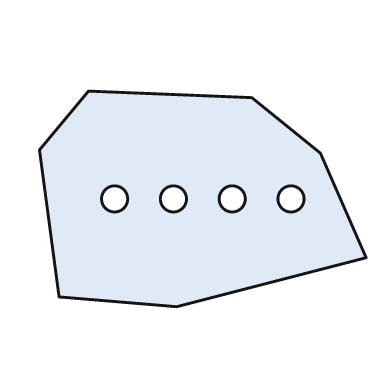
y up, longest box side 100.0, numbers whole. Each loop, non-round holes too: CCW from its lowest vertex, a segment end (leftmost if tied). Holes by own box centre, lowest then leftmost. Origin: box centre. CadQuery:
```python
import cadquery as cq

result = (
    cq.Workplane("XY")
    .moveTo(-8.0, -33.0)
    .lineTo(50.0, -18.0)
    .lineTo(36.0, 14.0)
    .lineTo(15.0, 31.0)
    .lineTo(-35.0, 33.0)
    .lineTo(-50.0, 15.0)
    .lineTo(-44.0, -30.0)
    .close()
    .moveTo(-27.0, 0.0)
    .circle(4.0)
    .moveTo(-9.0, 0.0)
    .circle(4.0)
    .moveTo(9.0, 0.0)
    .circle(4.0)
    .moveTo(27.0, 0.0)
    .circle(4.0)
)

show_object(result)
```